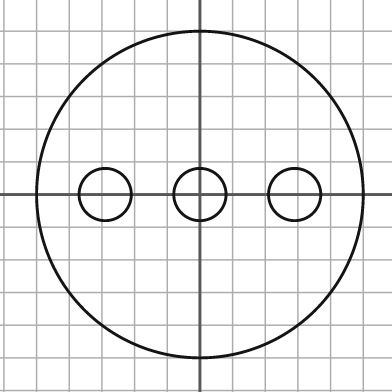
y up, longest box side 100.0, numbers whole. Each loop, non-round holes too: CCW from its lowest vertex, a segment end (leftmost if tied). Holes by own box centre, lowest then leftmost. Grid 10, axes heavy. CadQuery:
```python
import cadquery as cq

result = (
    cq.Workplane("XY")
    .moveTo(0.0, 0.0)
    .circle(50.0)
    .moveTo(-29.0, 0.0)
    .circle(8.0)
    .moveTo(0.0, 0.0)
    .circle(8.0)
    .moveTo(29.0, 0.0)
    .circle(8.0)
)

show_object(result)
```